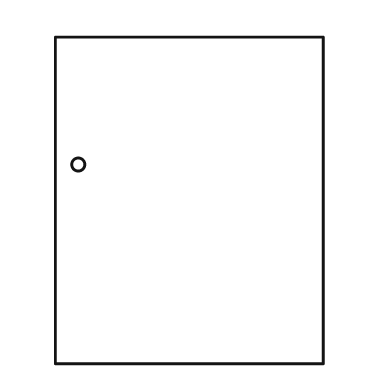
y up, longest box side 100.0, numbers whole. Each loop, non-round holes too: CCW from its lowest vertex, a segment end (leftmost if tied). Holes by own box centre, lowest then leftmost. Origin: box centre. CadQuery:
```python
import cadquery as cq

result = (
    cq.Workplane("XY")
    .moveTo(-41.0, -50.0)
    .lineTo(41.0, -50.0)
    .lineTo(41.0, 50.0)
    .lineTo(-41.0, 50.0)
    .close()
    .moveTo(-34.0, 11.0)
    .circle(2.0)
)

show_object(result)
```